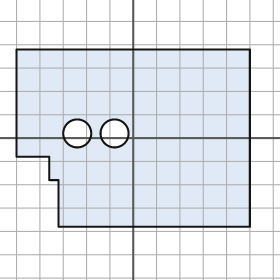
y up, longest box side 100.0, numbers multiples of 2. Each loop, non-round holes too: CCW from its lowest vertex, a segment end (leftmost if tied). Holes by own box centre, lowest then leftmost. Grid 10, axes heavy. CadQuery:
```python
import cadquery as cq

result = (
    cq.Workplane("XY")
    .moveTo(-32.0, -38.0)
    .lineTo(50.0, -38.0)
    .lineTo(50.0, 38.0)
    .lineTo(-50.0, 38.0)
    .lineTo(-50.0, -8.0)
    .lineTo(-36.0, -8.0)
    .lineTo(-36.0, -18.0)
    .lineTo(-32.0, -18.0)
    .close()
    .moveTo(-24.0, 2.0)
    .circle(6.0)
    .moveTo(-8.0, 2.0)
    .circle(6.0)
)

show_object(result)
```